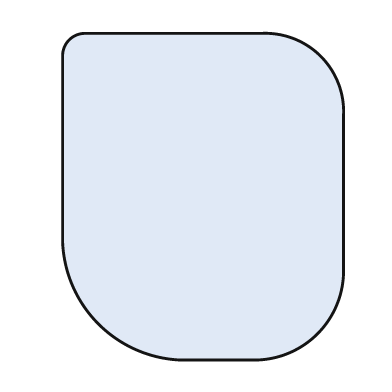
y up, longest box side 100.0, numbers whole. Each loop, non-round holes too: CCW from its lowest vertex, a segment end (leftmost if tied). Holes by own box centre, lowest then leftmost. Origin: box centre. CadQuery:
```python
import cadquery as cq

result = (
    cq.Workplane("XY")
    .moveTo(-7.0, -50.0)
    .lineTo(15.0, -50.0)
    .threePointArc((35.0, -42.0), (43.0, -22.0))
    .lineTo(43.0, 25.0)
    .threePointArc((36.0, 43.0), (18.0, 50.0))
    .lineTo(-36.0, 50.0)
    .threePointArc((-41.0, 48.0), (-43.0, 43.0))
    .lineTo(-43.0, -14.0)
    .threePointArc((-32.0, -39.0), (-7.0, -50.0))
    .close()
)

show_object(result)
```